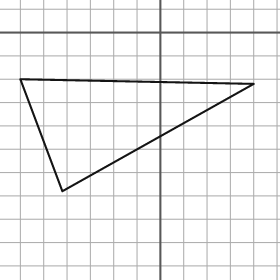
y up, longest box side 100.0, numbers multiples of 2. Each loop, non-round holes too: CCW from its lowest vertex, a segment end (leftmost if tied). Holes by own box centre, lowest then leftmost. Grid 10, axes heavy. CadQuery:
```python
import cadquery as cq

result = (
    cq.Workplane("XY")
    .moveTo(-42.0, -68.0)
    .lineTo(40.0, -22.0)
    .lineTo(-60.0, -20.0)
    .close()
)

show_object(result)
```